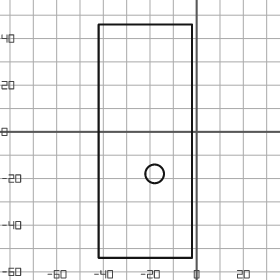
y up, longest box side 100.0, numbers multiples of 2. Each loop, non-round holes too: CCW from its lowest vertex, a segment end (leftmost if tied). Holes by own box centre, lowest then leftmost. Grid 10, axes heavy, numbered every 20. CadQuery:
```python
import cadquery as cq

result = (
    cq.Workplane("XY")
    .moveTo(-42.0, -54.0)
    .lineTo(-2.0, -54.0)
    .lineTo(-2.0, 46.0)
    .lineTo(-42.0, 46.0)
    .close()
    .moveTo(-18.0, -18.0)
    .circle(4.0)
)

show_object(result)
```